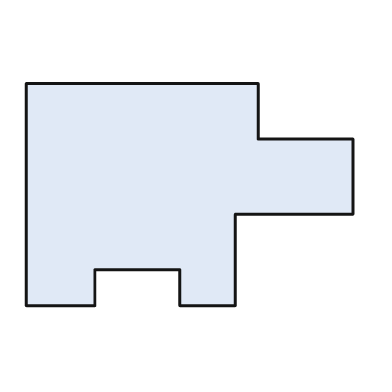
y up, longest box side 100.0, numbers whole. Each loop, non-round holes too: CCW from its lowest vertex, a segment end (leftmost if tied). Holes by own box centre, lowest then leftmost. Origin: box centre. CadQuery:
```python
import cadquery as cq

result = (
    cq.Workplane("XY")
    .moveTo(-50.0, -34.0)
    .lineTo(-29.0, -34.0)
    .lineTo(-29.0, -23.0)
    .lineTo(-3.0, -23.0)
    .lineTo(-3.0, -34.0)
    .lineTo(14.0, -34.0)
    .lineTo(14.0, -6.0)
    .lineTo(50.0, -6.0)
    .lineTo(50.0, 17.0)
    .lineTo(21.0, 17.0)
    .lineTo(21.0, 34.0)
    .lineTo(-50.0, 34.0)
    .close()
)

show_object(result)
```